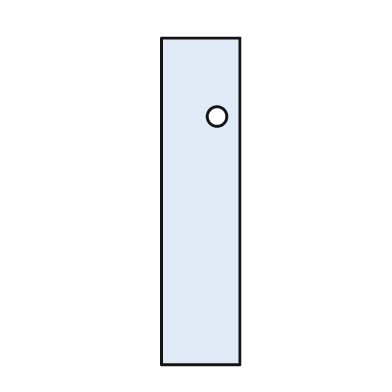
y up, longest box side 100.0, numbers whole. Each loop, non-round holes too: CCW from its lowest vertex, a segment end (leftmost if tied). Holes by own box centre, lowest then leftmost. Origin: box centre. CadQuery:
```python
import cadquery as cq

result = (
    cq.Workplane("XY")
    .moveTo(-12.0, -50.0)
    .lineTo(12.0, -50.0)
    .lineTo(12.0, 50.0)
    .lineTo(-12.0, 50.0)
    .close()
    .moveTo(5.0, 26.0)
    .circle(3.0)
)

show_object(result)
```